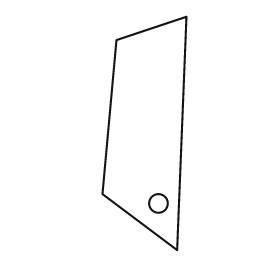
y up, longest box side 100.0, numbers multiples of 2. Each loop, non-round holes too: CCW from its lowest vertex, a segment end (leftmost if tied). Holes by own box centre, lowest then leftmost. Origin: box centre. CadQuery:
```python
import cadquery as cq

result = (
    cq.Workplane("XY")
    .moveTo(14.0, -50.0)
    .lineTo(18.0, 50.0)
    .lineTo(-12.0, 40.0)
    .lineTo(-18.0, -26.0)
    .close()
    .moveTo(6.0, -30.0)
    .circle(4.0)
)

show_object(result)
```